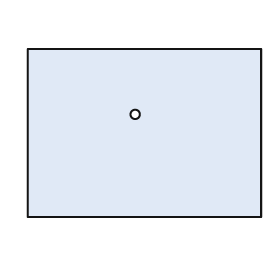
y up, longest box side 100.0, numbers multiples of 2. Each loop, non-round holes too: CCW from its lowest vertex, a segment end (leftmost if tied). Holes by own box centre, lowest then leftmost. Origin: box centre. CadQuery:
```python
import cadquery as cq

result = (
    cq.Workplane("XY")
    .moveTo(-50.0, -36.0)
    .lineTo(50.0, -36.0)
    .lineTo(50.0, 36.0)
    .lineTo(-50.0, 36.0)
    .close()
    .moveTo(-4.0, 8.0)
    .circle(2.0)
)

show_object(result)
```